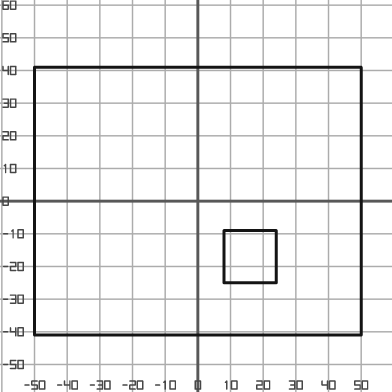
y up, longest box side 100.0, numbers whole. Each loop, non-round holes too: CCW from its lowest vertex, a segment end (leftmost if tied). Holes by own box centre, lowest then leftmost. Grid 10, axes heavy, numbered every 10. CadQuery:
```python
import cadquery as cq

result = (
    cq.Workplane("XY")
    .moveTo(-50.0, -41.0)
    .lineTo(50.0, -41.0)
    .lineTo(50.0, 41.0)
    .lineTo(-50.0, 41.0)
    .close()
    .moveTo(8.0, -25.0)
    .lineTo(24.0, -25.0)
    .lineTo(24.0, -9.0)
    .lineTo(8.0, -9.0)
    .close()
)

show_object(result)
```